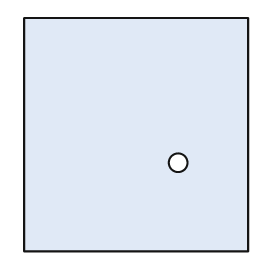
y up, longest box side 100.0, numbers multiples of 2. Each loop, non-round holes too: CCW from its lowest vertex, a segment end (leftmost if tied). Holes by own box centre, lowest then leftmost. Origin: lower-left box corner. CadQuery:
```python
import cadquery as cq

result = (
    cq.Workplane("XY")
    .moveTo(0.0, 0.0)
    .lineTo(96.0, 0.0)
    .lineTo(96.0, 100.0)
    .lineTo(0.0, 100.0)
    .close()
    .moveTo(66.0, 38.0)
    .circle(4.0)
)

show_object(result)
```